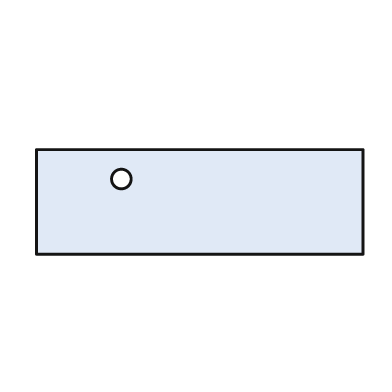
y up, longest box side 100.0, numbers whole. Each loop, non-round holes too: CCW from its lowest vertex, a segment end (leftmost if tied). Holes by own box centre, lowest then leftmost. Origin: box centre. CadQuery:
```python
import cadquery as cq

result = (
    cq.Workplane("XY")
    .moveTo(-50.0, -16.0)
    .lineTo(50.0, -16.0)
    .lineTo(50.0, 16.0)
    .lineTo(-50.0, 16.0)
    .close()
    .moveTo(-24.0, 7.0)
    .circle(3.0)
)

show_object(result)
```